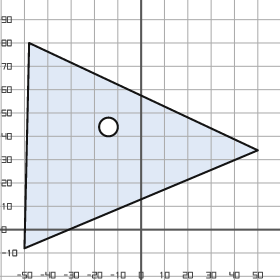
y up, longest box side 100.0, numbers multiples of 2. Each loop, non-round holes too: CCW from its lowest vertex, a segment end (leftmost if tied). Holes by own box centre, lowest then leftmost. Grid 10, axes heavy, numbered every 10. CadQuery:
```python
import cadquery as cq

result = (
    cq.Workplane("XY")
    .moveTo(-50.0, -8.0)
    .lineTo(50.0, 34.0)
    .lineTo(-48.0, 80.0)
    .close()
    .moveTo(-14.0, 44.0)
    .circle(4.0)
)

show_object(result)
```